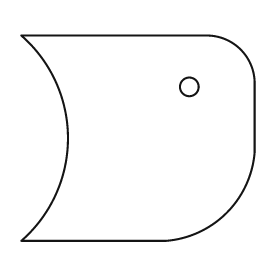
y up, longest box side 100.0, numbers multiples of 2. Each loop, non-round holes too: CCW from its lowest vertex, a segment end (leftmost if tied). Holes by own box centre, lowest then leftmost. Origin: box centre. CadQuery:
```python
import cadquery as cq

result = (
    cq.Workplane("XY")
    .moveTo(-50.0, -44.0)
    .lineTo(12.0, -44.0)
    .threePointArc((38.0, -32.0), (50.0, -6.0))
    .lineTo(50.0, 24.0)
    .threePointArc((44.0, 38.0), (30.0, 44.0))
    .lineTo(-50.0, 44.0)
    .threePointArc((-30.0, 0.0), (-50.0, -44.0))
    .close()
    .moveTo(22.0, 22.0)
    .circle(4.0)
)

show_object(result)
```